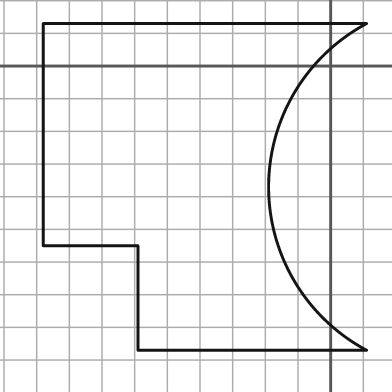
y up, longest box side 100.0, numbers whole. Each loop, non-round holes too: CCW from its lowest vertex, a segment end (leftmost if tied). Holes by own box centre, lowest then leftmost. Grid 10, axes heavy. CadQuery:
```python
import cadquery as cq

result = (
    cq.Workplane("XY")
    .moveTo(-59.0, -87.0)
    .lineTo(11.0, -87.0)
    .threePointArc((-19.0, -37.0), (11.0, 13.0))
    .lineTo(-88.0, 13.0)
    .lineTo(-88.0, -55.0)
    .lineTo(-59.0, -55.0)
    .close()
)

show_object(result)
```